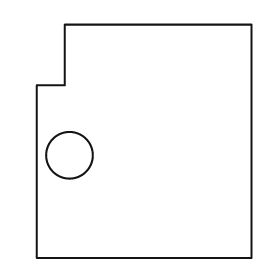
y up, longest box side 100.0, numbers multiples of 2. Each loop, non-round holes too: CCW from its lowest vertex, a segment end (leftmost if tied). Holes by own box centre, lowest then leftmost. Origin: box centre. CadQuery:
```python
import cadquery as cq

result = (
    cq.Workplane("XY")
    .moveTo(-46.0, -50.0)
    .lineTo(46.0, -50.0)
    .lineTo(46.0, 50.0)
    .lineTo(-34.0, 50.0)
    .lineTo(-34.0, 24.0)
    .lineTo(-46.0, 24.0)
    .close()
    .moveTo(-32.0, -6.0)
    .circle(10.0)
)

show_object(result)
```